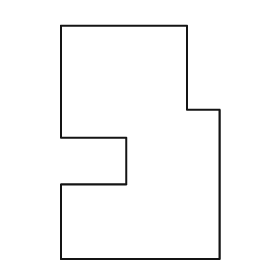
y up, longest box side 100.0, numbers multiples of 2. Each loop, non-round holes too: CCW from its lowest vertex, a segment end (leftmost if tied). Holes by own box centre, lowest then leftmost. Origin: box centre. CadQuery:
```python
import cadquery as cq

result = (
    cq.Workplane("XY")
    .moveTo(-34.0, -50.0)
    .lineTo(34.0, -50.0)
    .lineTo(34.0, 14.0)
    .lineTo(20.0, 14.0)
    .lineTo(20.0, 50.0)
    .lineTo(-34.0, 50.0)
    .lineTo(-34.0, 2.0)
    .lineTo(-6.0, 2.0)
    .lineTo(-6.0, -18.0)
    .lineTo(-34.0, -18.0)
    .close()
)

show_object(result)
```